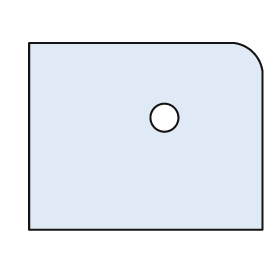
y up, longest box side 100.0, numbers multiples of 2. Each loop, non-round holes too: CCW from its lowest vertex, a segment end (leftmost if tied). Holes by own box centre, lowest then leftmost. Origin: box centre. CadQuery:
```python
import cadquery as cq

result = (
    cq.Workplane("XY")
    .moveTo(-50.0, -40.0)
    .lineTo(50.0, -40.0)
    .lineTo(50.0, 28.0)
    .threePointArc((46.0, 36.0), (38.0, 40.0))
    .lineTo(-50.0, 40.0)
    .close()
    .moveTo(8.0, 8.0)
    .circle(6.0)
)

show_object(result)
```